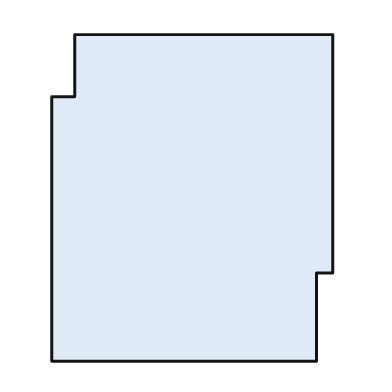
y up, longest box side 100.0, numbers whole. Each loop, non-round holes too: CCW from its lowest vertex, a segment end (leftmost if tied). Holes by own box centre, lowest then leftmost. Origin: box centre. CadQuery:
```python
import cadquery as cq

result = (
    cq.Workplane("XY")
    .moveTo(-43.0, -50.0)
    .lineTo(38.0, -50.0)
    .lineTo(38.0, -23.0)
    .lineTo(43.0, -23.0)
    .lineTo(43.0, 50.0)
    .lineTo(-36.0, 50.0)
    .lineTo(-36.0, 31.0)
    .lineTo(-43.0, 31.0)
    .close()
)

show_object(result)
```